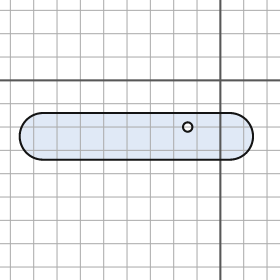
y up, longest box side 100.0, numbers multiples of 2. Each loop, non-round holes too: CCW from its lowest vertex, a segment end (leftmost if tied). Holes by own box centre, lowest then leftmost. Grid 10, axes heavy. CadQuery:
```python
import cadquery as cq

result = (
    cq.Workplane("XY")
    .moveTo(-76.0, -34.0)
    .lineTo(4.0, -34.0)
    .threePointArc((14.0, -24.0), (4.0, -14.0))
    .lineTo(-76.0, -14.0)
    .threePointArc((-86.0, -24.0), (-76.0, -34.0))
    .close()
    .moveTo(-14.0, -20.0)
    .circle(2.0)
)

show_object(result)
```